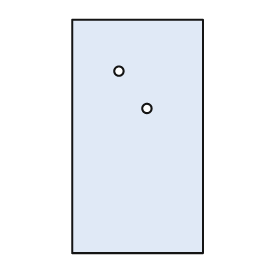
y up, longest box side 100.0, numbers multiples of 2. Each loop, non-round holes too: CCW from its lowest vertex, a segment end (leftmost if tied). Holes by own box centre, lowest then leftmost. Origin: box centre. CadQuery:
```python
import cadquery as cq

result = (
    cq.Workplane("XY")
    .moveTo(-28.0, -50.0)
    .lineTo(28.0, -50.0)
    .lineTo(28.0, 50.0)
    .lineTo(-28.0, 50.0)
    .close()
    .moveTo(4.0, 12.0)
    .circle(2.0)
    .moveTo(-8.0, 28.0)
    .circle(2.0)
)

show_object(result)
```